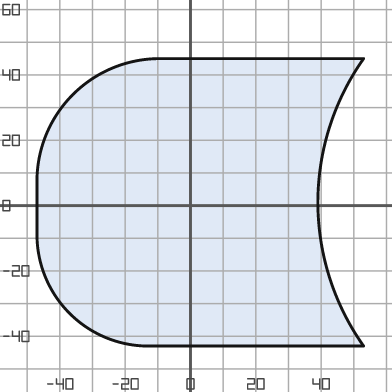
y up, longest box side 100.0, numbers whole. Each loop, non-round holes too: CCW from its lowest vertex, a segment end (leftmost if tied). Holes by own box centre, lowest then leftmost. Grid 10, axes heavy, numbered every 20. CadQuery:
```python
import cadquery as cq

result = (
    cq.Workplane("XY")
    .moveTo(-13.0, -43.0)
    .lineTo(53.0, -43.0)
    .threePointArc((39.0, 1.0), (53.0, 45.0))
    .lineTo(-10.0, 45.0)
    .threePointArc((-36.0, 34.0), (-47.0, 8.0))
    .lineTo(-47.0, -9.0)
    .threePointArc((-37.0, -33.0), (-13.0, -43.0))
    .close()
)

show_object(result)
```